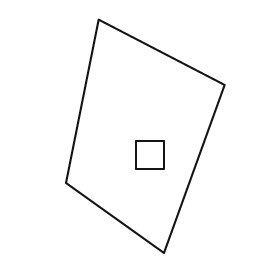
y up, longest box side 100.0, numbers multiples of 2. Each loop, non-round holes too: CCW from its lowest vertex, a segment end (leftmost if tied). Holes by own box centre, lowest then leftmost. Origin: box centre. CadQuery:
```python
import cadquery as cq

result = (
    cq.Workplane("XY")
    .moveTo(8.0, -50.0)
    .lineTo(34.0, 22.0)
    .lineTo(-20.0, 50.0)
    .lineTo(-34.0, -20.0)
    .close()
    .moveTo(-4.0, -14.0)
    .lineTo(8.0, -14.0)
    .lineTo(8.0, -2.0)
    .lineTo(-4.0, -2.0)
    .close()
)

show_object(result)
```